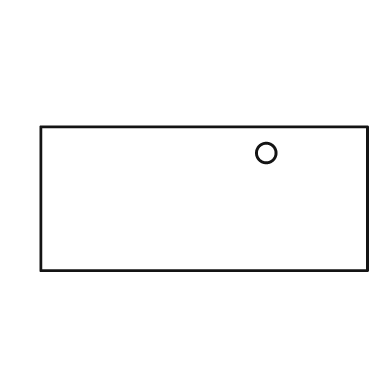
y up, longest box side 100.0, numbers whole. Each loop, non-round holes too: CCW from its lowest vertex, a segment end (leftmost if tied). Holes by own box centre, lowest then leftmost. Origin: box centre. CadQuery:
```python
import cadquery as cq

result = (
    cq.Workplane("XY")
    .moveTo(-50.0, -22.0)
    .lineTo(50.0, -22.0)
    .lineTo(50.0, 22.0)
    .lineTo(-50.0, 22.0)
    .close()
    .moveTo(19.0, 14.0)
    .circle(3.0)
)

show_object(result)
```